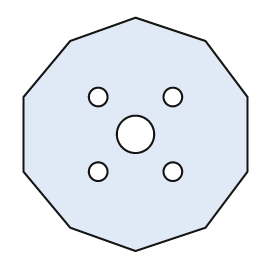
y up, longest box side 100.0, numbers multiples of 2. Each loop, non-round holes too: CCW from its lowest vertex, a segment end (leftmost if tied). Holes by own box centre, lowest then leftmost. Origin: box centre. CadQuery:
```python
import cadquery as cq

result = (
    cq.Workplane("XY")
    .moveTo(0.0, -50.0)
    .lineTo(30.0, -40.0)
    .lineTo(48.0, -16.0)
    .lineTo(48.0, 16.0)
    .lineTo(30.0, 40.0)
    .lineTo(0.0, 50.0)
    .lineTo(-28.0, 40.0)
    .lineTo(-48.0, 16.0)
    .lineTo(-48.0, -16.0)
    .lineTo(-28.0, -40.0)
    .close()
    .moveTo(-16.0, -16.0)
    .circle(4.0)
    .moveTo(16.0, -16.0)
    .circle(4.0)
    .moveTo(0.0, 0.0)
    .circle(8.0)
    .moveTo(-16.0, 16.0)
    .circle(4.0)
    .moveTo(16.0, 16.0)
    .circle(4.0)
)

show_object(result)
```